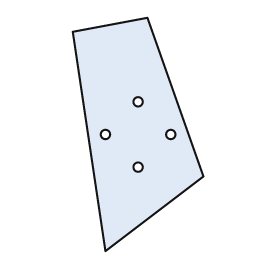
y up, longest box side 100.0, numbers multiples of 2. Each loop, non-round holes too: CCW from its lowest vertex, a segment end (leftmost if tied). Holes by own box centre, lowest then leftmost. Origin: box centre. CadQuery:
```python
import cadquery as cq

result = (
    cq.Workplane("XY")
    .moveTo(-14.0, -50.0)
    .lineTo(28.0, -18.0)
    .lineTo(4.0, 50.0)
    .lineTo(-28.0, 44.0)
    .close()
    .moveTo(0.0, -14.0)
    .circle(2.0)
    .moveTo(-14.0, 0.0)
    .circle(2.0)
    .moveTo(14.0, 0.0)
    .circle(2.0)
    .moveTo(0.0, 14.0)
    .circle(2.0)
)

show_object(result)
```